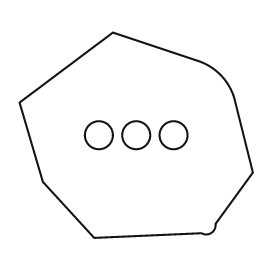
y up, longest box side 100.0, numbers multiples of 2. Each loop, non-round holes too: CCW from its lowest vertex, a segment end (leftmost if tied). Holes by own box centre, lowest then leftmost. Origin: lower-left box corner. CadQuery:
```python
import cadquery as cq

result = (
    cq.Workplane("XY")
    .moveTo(32.0, 0.0)
    .lineTo(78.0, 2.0)
    .threePointArc((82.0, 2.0), (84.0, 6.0))
    .lineTo(100.0, 28.0)
    .lineTo(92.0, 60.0)
    .threePointArc((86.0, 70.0), (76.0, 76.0))
    .lineTo(40.0, 88.0)
    .lineTo(0.0, 58.0)
    .lineTo(10.0, 24.0)
    .close()
    .moveTo(34.0, 44.0)
    .circle(6.0)
    .moveTo(50.0, 44.0)
    .circle(6.0)
    .moveTo(66.0, 44.0)
    .circle(6.0)
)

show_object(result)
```